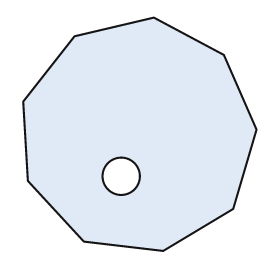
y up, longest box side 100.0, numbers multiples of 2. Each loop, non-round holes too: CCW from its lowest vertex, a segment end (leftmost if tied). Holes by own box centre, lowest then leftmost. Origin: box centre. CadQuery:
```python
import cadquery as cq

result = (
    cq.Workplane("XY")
    .moveTo(10.0, -50.0)
    .lineTo(40.0, -32.0)
    .lineTo(50.0, 2.0)
    .lineTo(36.0, 34.0)
    .lineTo(6.0, 50.0)
    .lineTo(-28.0, 42.0)
    .lineTo(-50.0, 14.0)
    .lineTo(-48.0, -20.0)
    .lineTo(-24.0, -46.0)
    .close()
    .moveTo(-8.0, -18.0)
    .circle(8.0)
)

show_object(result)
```